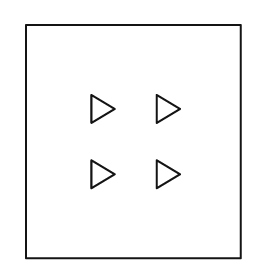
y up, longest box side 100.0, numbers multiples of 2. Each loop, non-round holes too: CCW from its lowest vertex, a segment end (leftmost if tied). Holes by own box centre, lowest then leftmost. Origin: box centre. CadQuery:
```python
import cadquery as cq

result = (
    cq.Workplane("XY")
    .moveTo(-46.0, -50.0)
    .lineTo(46.0, -50.0)
    .lineTo(46.0, 50.0)
    .lineTo(-46.0, 50.0)
    .close()
    .moveTo(-18.0, -20.0)
    .lineTo(-8.0, -14.0)
    .lineTo(-18.0, -8.0)
    .close()
    .moveTo(10.0, -20.0)
    .lineTo(20.0, -14.0)
    .lineTo(10.0, -8.0)
    .close()
    .moveTo(-18.0, 8.0)
    .lineTo(-8.0, 14.0)
    .lineTo(-18.0, 20.0)
    .close()
    .moveTo(10.0, 8.0)
    .lineTo(20.0, 14.0)
    .lineTo(10.0, 20.0)
    .close()
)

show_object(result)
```